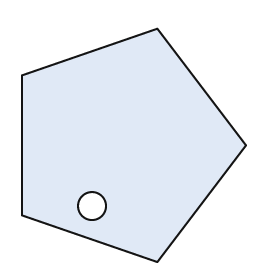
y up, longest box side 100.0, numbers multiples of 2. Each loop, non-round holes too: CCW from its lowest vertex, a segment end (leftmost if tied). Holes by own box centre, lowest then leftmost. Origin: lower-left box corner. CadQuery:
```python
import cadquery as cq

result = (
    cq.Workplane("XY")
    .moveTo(58.0, 0.0)
    .lineTo(96.0, 50.0)
    .lineTo(58.0, 100.0)
    .lineTo(0.0, 80.0)
    .lineTo(0.0, 20.0)
    .close()
    .moveTo(30.0, 24.0)
    .circle(6.0)
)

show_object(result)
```